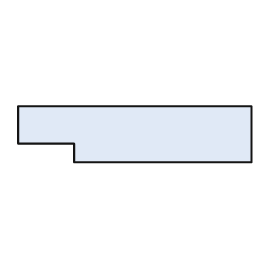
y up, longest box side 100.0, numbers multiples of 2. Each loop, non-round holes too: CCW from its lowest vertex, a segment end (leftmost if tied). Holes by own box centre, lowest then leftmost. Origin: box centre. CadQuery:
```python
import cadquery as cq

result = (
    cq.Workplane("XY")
    .moveTo(-26.0, -12.0)
    .lineTo(50.0, -12.0)
    .lineTo(50.0, 12.0)
    .lineTo(-50.0, 12.0)
    .lineTo(-50.0, -4.0)
    .lineTo(-26.0, -4.0)
    .close()
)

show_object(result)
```